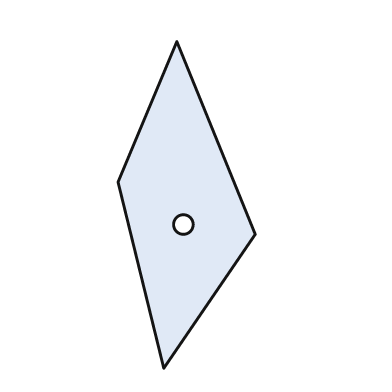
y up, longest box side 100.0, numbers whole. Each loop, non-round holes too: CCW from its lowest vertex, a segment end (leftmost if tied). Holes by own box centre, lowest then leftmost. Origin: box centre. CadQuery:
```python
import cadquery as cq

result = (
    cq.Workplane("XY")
    .moveTo(-7.0, -50.0)
    .lineTo(21.0, -9.0)
    .lineTo(-3.0, 50.0)
    .lineTo(-21.0, 7.0)
    .close()
    .moveTo(-1.0, -6.0)
    .circle(3.0)
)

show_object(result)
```